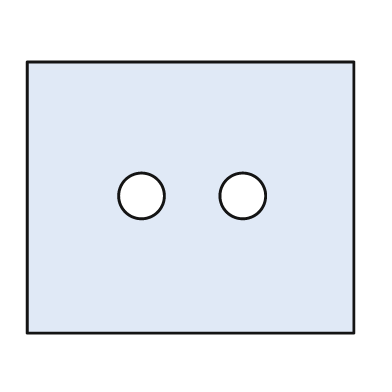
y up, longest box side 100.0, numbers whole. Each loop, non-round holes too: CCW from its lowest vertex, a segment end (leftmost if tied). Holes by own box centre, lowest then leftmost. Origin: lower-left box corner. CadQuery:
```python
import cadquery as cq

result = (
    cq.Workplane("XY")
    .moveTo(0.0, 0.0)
    .lineTo(100.0, 0.0)
    .lineTo(100.0, 83.0)
    .lineTo(0.0, 83.0)
    .close()
    .moveTo(35.0, 42.0)
    .circle(7.0)
    .moveTo(66.0, 42.0)
    .circle(7.0)
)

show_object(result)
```